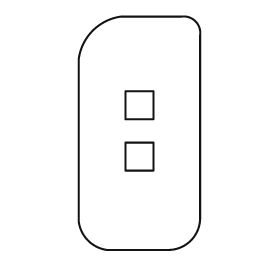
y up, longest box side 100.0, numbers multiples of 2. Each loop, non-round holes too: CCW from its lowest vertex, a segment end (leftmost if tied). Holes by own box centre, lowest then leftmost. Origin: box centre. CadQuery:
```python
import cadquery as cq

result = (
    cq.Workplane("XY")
    .moveTo(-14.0, -50.0)
    .lineTo(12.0, -50.0)
    .threePointArc((22.0, -46.0), (26.0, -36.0))
    .lineTo(26.0, 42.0)
    .threePointArc((24.0, 48.0), (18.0, 50.0))
    .lineTo(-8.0, 50.0)
    .threePointArc((-20.0, 44.0), (-26.0, 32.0))
    .lineTo(-26.0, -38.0)
    .threePointArc((-22.0, -46.0), (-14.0, -50.0))
    .close()
    .moveTo(-6.0, -16.0)
    .lineTo(6.0, -16.0)
    .lineTo(6.0, -4.0)
    .lineTo(-6.0, -4.0)
    .close()
    .moveTo(-6.0, 6.0)
    .lineTo(6.0, 6.0)
    .lineTo(6.0, 18.0)
    .lineTo(-6.0, 18.0)
    .close()
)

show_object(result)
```